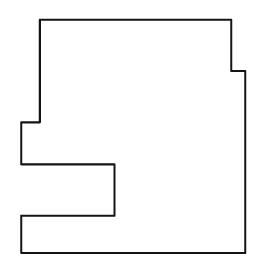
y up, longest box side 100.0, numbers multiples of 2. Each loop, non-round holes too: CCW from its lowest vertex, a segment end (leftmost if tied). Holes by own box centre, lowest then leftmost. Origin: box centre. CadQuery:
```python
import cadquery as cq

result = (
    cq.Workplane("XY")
    .moveTo(-48.0, -50.0)
    .lineTo(48.0, -50.0)
    .lineTo(48.0, 28.0)
    .lineTo(42.0, 28.0)
    .lineTo(42.0, 50.0)
    .lineTo(-40.0, 50.0)
    .lineTo(-40.0, 6.0)
    .lineTo(-48.0, 6.0)
    .lineTo(-48.0, -12.0)
    .lineTo(-8.0, -12.0)
    .lineTo(-8.0, -34.0)
    .lineTo(-48.0, -34.0)
    .close()
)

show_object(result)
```